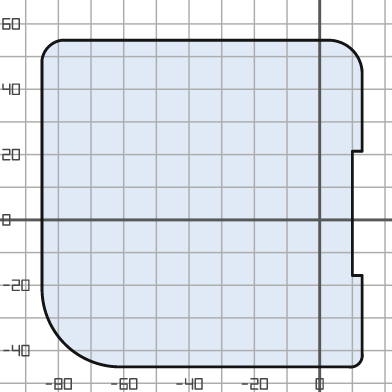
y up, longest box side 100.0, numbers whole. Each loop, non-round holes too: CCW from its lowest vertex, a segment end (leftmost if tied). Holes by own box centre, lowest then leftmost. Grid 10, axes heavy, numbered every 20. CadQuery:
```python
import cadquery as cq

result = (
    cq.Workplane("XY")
    .moveTo(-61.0, -45.0)
    .lineTo(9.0, -45.0)
    .threePointArc((12.0, -44.0), (13.0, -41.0))
    .lineTo(13.0, -17.0)
    .lineTo(10.0, -17.0)
    .lineTo(10.0, 21.0)
    .lineTo(13.0, 21.0)
    .lineTo(13.0, 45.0)
    .threePointArc((10.0, 52.0), (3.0, 55.0))
    .lineTo(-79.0, 55.0)
    .threePointArc((-83.0, 53.0), (-85.0, 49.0))
    .lineTo(-85.0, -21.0)
    .threePointArc((-78.0, -38.0), (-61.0, -45.0))
    .close()
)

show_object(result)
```